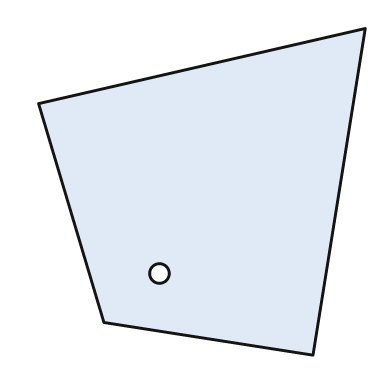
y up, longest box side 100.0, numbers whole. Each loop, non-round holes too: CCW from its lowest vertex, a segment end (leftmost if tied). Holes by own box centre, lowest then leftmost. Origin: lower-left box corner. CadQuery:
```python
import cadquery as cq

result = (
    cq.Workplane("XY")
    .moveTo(84.0, 0.0)
    .lineTo(100.0, 100.0)
    .lineTo(0.0, 77.0)
    .lineTo(20.0, 10.0)
    .close()
    .moveTo(37.0, 25.0)
    .circle(3.0)
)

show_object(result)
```